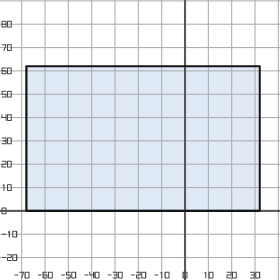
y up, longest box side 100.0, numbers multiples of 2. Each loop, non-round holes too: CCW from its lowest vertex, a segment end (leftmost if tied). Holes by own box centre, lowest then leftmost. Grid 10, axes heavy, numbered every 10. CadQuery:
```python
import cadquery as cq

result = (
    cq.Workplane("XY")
    .moveTo(-68.0, 0.0)
    .lineTo(32.0, 0.0)
    .lineTo(32.0, 62.0)
    .lineTo(-68.0, 62.0)
    .close()
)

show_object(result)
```